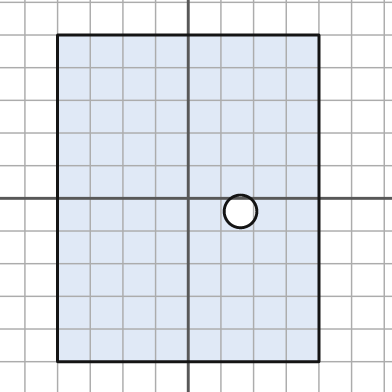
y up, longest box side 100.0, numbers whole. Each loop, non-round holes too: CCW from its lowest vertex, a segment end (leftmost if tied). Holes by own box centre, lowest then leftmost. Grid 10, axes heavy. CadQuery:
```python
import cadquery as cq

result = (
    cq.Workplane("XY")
    .moveTo(-40.0, -50.0)
    .lineTo(40.0, -50.0)
    .lineTo(40.0, 50.0)
    .lineTo(-40.0, 50.0)
    .close()
    .moveTo(16.0, -4.0)
    .circle(5.0)
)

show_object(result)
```